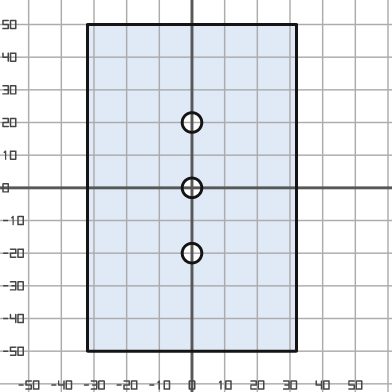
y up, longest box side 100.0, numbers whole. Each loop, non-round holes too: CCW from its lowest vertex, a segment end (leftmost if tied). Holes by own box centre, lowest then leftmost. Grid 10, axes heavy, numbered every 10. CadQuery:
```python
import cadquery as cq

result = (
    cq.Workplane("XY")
    .moveTo(-32.0, -50.0)
    .lineTo(32.0, -50.0)
    .lineTo(32.0, 50.0)
    .lineTo(-32.0, 50.0)
    .close()
    .moveTo(0.0, -20.0)
    .circle(3.0)
    .moveTo(0.0, 0.0)
    .circle(3.0)
    .moveTo(0.0, 20.0)
    .circle(3.0)
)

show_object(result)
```